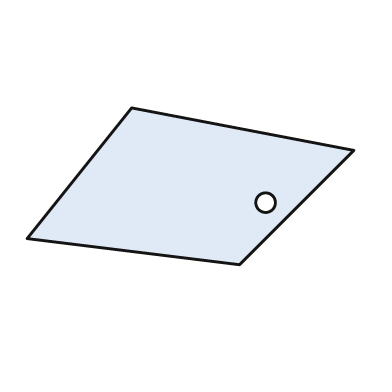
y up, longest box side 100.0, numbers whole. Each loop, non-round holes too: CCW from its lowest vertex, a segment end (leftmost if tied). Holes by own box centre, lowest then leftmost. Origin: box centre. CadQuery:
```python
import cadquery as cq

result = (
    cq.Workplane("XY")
    .moveTo(15.0, -24.0)
    .lineTo(50.0, 11.0)
    .lineTo(-18.0, 24.0)
    .lineTo(-50.0, -16.0)
    .close()
    .moveTo(23.0, -5.0)
    .circle(3.0)
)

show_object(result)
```